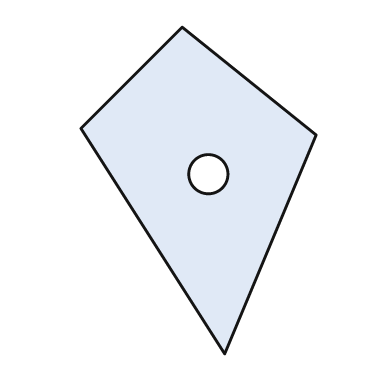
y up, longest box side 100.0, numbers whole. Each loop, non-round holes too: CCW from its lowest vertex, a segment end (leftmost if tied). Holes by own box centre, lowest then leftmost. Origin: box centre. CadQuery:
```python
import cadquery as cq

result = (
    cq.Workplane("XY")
    .moveTo(8.0, -50.0)
    .lineTo(36.0, 17.0)
    .lineTo(-5.0, 50.0)
    .lineTo(-36.0, 19.0)
    .close()
    .moveTo(3.0, 5.0)
    .circle(6.0)
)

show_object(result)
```